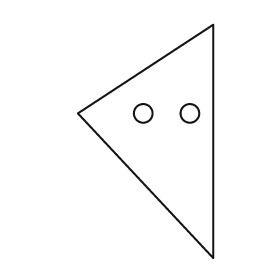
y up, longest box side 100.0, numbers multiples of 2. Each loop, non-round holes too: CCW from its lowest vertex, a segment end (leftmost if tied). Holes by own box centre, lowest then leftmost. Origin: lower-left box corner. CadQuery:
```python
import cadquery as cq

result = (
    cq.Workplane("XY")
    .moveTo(58.0, 0.0)
    .lineTo(58.0, 100.0)
    .lineTo(0.0, 62.0)
    .close()
    .moveTo(28.0, 62.0)
    .circle(4.0)
    .moveTo(48.0, 62.0)
    .circle(4.0)
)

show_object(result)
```